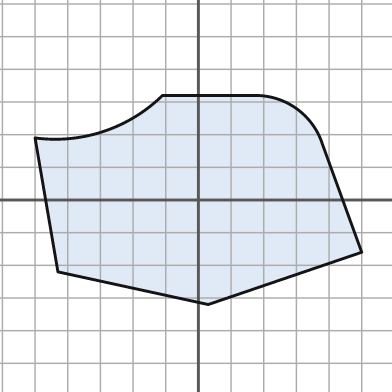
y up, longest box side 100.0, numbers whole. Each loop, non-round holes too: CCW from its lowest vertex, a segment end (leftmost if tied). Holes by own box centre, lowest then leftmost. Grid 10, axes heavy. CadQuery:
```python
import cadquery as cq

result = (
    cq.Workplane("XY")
    .moveTo(3.0, -32.0)
    .lineTo(50.0, -16.0)
    .lineTo(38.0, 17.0)
    .threePointArc((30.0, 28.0), (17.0, 32.0))
    .lineTo(-11.0, 32.0)
    .threePointArc((-29.0, 21.0), (-50.0, 19.0))
    .lineTo(-43.0, -22.0)
    .close()
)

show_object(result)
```